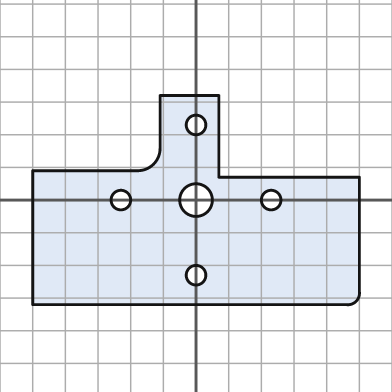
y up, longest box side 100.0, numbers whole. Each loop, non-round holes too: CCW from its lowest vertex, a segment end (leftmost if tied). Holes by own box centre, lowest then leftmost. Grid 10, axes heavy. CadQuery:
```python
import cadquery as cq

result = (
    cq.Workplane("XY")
    .moveTo(-50.0, -32.0)
    .lineTo(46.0, -32.0)
    .threePointArc((49.0, -31.0), (50.0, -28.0))
    .lineTo(50.0, 7.0)
    .lineTo(7.0, 7.0)
    .lineTo(7.0, 32.0)
    .lineTo(-11.0, 32.0)
    .lineTo(-11.0, 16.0)
    .threePointArc((-13.0, 11.0), (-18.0, 9.0))
    .lineTo(-50.0, 9.0)
    .close()
    .moveTo(0.0, -23.0)
    .circle(3.0)
    .moveTo(-23.0, 0.0)
    .circle(3.0)
    .moveTo(0.0, 0.0)
    .circle(5.0)
    .moveTo(23.0, 0.0)
    .circle(3.0)
    .moveTo(0.0, 23.0)
    .circle(3.0)
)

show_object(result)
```